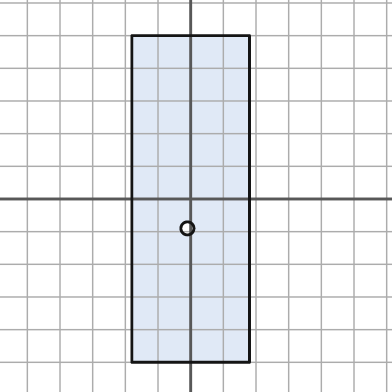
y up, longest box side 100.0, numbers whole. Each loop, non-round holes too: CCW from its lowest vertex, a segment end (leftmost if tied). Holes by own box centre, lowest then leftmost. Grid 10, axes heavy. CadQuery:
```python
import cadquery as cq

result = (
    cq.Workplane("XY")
    .moveTo(-18.0, -50.0)
    .lineTo(18.0, -50.0)
    .lineTo(18.0, 50.0)
    .lineTo(-18.0, 50.0)
    .close()
    .moveTo(-1.0, -9.0)
    .circle(2.0)
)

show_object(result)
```